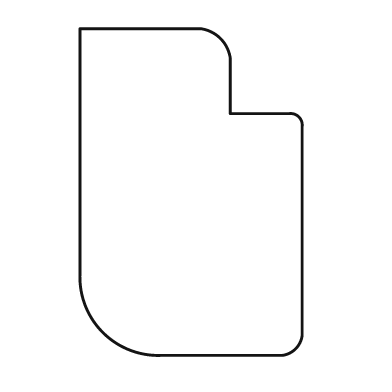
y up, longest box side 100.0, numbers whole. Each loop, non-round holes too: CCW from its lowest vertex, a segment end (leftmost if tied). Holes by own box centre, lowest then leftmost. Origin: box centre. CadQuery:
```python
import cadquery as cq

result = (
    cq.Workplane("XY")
    .moveTo(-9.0, -50.0)
    .lineTo(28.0, -50.0)
    .threePointArc((32.0, -48.0), (34.0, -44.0))
    .lineTo(34.0, 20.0)
    .threePointArc((33.0, 23.0), (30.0, 24.0))
    .lineTo(12.0, 24.0)
    .lineTo(12.0, 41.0)
    .threePointArc((9.0, 47.0), (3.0, 50.0))
    .lineTo(-34.0, 50.0)
    .lineTo(-34.0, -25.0)
    .threePointArc((-27.0, -43.0), (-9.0, -50.0))
    .close()
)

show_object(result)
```